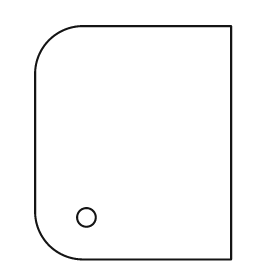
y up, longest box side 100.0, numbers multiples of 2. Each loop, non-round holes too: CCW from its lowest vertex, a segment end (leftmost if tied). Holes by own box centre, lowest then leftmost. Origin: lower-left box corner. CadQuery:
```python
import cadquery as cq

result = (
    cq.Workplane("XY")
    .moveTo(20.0, 0.0)
    .lineTo(84.0, 0.0)
    .lineTo(84.0, 100.0)
    .lineTo(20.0, 100.0)
    .threePointArc((6.0, 94.0), (0.0, 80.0))
    .lineTo(0.0, 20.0)
    .threePointArc((6.0, 6.0), (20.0, 0.0))
    .close()
    .moveTo(22.0, 18.0)
    .circle(4.0)
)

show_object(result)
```